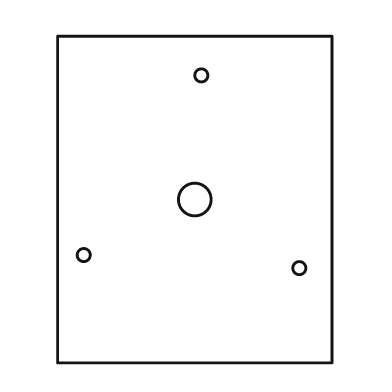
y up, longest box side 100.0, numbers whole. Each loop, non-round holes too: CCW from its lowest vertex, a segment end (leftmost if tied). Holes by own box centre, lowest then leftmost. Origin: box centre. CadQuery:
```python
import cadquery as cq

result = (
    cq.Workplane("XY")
    .moveTo(-42.0, -50.0)
    .lineTo(42.0, -50.0)
    .lineTo(42.0, 50.0)
    .lineTo(-42.0, 50.0)
    .close()
    .moveTo(32.0, -21.0)
    .circle(2.0)
    .moveTo(-34.0, -17.0)
    .circle(2.0)
    .moveTo(0.0, 0.0)
    .circle(5.0)
    .moveTo(2.0, 38.0)
    .circle(2.0)
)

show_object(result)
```